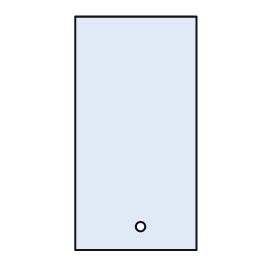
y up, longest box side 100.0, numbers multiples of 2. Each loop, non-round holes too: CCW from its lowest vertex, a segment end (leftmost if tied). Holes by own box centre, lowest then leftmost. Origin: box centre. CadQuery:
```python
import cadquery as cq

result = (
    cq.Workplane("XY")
    .moveTo(-26.0, -50.0)
    .lineTo(26.0, -50.0)
    .lineTo(26.0, 50.0)
    .lineTo(-26.0, 50.0)
    .close()
    .moveTo(2.0, -40.0)
    .circle(2.0)
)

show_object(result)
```